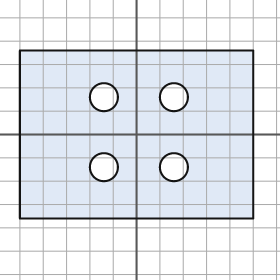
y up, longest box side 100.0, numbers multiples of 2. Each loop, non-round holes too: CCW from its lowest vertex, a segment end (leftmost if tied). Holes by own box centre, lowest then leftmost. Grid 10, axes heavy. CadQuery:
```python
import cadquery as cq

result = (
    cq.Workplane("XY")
    .moveTo(-50.0, -36.0)
    .lineTo(50.0, -36.0)
    .lineTo(50.0, 36.0)
    .lineTo(-50.0, 36.0)
    .close()
    .moveTo(-14.0, -14.0)
    .circle(6.0)
    .moveTo(16.0, -14.0)
    .circle(6.0)
    .moveTo(-14.0, 16.0)
    .circle(6.0)
    .moveTo(16.0, 16.0)
    .circle(6.0)
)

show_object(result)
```